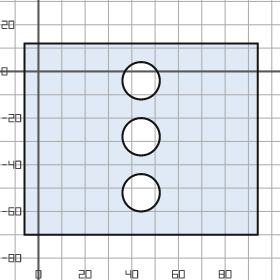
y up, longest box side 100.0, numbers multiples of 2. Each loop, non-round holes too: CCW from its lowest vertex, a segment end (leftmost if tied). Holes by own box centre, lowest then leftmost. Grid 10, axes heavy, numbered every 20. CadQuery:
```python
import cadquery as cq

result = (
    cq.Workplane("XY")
    .moveTo(-6.0, -70.0)
    .lineTo(94.0, -70.0)
    .lineTo(94.0, 12.0)
    .lineTo(-6.0, 12.0)
    .close()
    .moveTo(44.0, -52.0)
    .circle(8.0)
    .moveTo(44.0, -28.0)
    .circle(8.0)
    .moveTo(44.0, -4.0)
    .circle(8.0)
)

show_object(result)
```